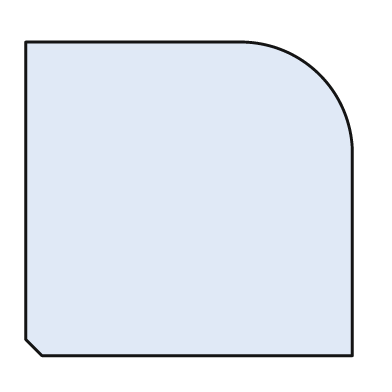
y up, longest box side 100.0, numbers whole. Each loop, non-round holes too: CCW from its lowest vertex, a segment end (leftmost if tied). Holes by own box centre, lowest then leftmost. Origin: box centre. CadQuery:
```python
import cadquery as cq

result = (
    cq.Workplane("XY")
    .moveTo(-45.0, -48.0)
    .lineTo(50.0, -48.0)
    .lineTo(50.0, 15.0)
    .threePointArc((40.0, 38.0), (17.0, 48.0))
    .lineTo(-50.0, 48.0)
    .lineTo(-50.0, -43.0)
    .close()
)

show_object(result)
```